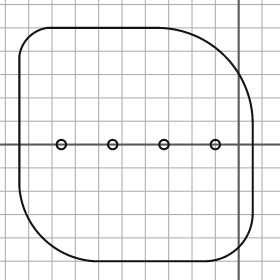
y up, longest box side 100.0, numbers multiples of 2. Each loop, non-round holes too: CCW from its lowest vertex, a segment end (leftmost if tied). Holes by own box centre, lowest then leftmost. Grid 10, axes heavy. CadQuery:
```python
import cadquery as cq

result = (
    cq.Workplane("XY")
    .moveTo(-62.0, -50.0)
    .lineTo(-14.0, -50.0)
    .threePointArc((0.0, -44.0), (6.0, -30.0))
    .lineTo(6.0, 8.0)
    .threePointArc((-6.0, 38.0), (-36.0, 50.0))
    .lineTo(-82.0, 50.0)
    .threePointArc((-90.0, 46.0), (-94.0, 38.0))
    .lineTo(-94.0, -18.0)
    .threePointArc((-84.0, -40.0), (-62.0, -50.0))
    .close()
    .moveTo(-76.0, 0.0)
    .circle(2.0)
    .moveTo(-54.0, 0.0)
    .circle(2.0)
    .moveTo(-32.0, 0.0)
    .circle(2.0)
    .moveTo(-10.0, 0.0)
    .circle(2.0)
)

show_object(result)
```